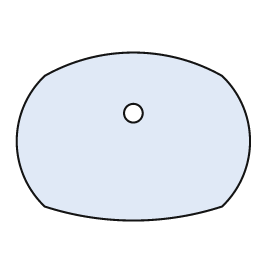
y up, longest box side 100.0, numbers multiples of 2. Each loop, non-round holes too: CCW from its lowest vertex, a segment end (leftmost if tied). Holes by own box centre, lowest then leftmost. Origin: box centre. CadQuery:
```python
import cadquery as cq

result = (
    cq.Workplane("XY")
    .moveTo(-38.0, -30.0)
    .threePointArc((0.0, -36.0), (38.0, -30.0))
    .threePointArc((50.0, -2.0), (38.0, 26.0))
    .threePointArc((0.0, 36.0), (-38.0, 26.0))
    .threePointArc((-50.0, -2.0), (-38.0, -30.0))
    .close()
    .moveTo(0.0, 10.0)
    .circle(4.0)
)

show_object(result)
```